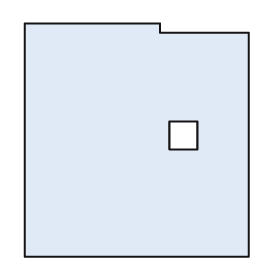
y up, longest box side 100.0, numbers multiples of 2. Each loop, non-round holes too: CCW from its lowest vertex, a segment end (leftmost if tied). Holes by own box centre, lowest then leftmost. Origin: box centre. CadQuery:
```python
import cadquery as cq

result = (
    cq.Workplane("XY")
    .moveTo(-48.0, -50.0)
    .lineTo(48.0, -50.0)
    .lineTo(48.0, 46.0)
    .lineTo(10.0, 46.0)
    .lineTo(10.0, 50.0)
    .lineTo(-48.0, 50.0)
    .close()
    .moveTo(14.0, -4.0)
    .lineTo(26.0, -4.0)
    .lineTo(26.0, 8.0)
    .lineTo(14.0, 8.0)
    .close()
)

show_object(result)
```